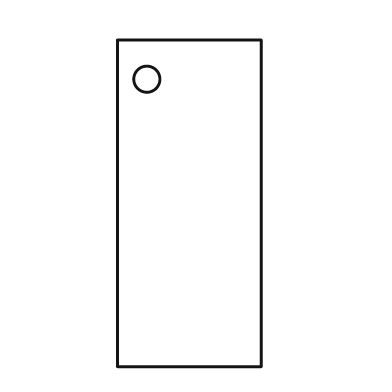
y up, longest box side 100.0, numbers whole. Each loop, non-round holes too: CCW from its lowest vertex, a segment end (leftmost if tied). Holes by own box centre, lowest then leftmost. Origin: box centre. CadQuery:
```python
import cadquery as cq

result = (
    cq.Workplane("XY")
    .moveTo(-22.0, -50.0)
    .lineTo(22.0, -50.0)
    .lineTo(22.0, 50.0)
    .lineTo(-22.0, 50.0)
    .close()
    .moveTo(-13.0, 38.0)
    .circle(4.0)
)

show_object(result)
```